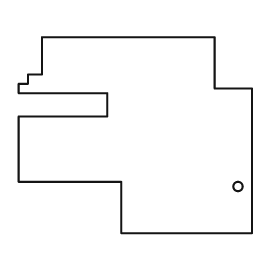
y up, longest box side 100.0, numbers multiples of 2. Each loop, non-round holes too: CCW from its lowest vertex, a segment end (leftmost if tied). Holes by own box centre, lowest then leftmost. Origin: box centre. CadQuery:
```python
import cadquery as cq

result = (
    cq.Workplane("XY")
    .moveTo(-6.0, -42.0)
    .lineTo(50.0, -42.0)
    .lineTo(50.0, 20.0)
    .lineTo(34.0, 20.0)
    .lineTo(34.0, 42.0)
    .lineTo(-40.0, 42.0)
    .lineTo(-40.0, 26.0)
    .lineTo(-46.0, 26.0)
    .lineTo(-46.0, 22.0)
    .lineTo(-50.0, 22.0)
    .lineTo(-50.0, 18.0)
    .lineTo(-12.0, 18.0)
    .lineTo(-12.0, 8.0)
    .lineTo(-50.0, 8.0)
    .lineTo(-50.0, -20.0)
    .lineTo(-6.0, -20.0)
    .close()
    .moveTo(44.0, -22.0)
    .circle(2.0)
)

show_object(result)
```